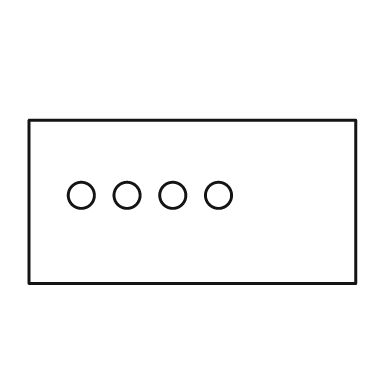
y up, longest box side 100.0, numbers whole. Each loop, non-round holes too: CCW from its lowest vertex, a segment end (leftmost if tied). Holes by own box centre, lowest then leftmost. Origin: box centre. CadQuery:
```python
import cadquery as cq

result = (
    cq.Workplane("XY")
    .moveTo(-50.0, -25.0)
    .lineTo(50.0, -25.0)
    .lineTo(50.0, 25.0)
    .lineTo(-50.0, 25.0)
    .close()
    .moveTo(-34.0, 2.0)
    .circle(4.0)
    .moveTo(-20.0, 2.0)
    .circle(4.0)
    .moveTo(-6.0, 2.0)
    .circle(4.0)
    .moveTo(8.0, 2.0)
    .circle(4.0)
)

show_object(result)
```